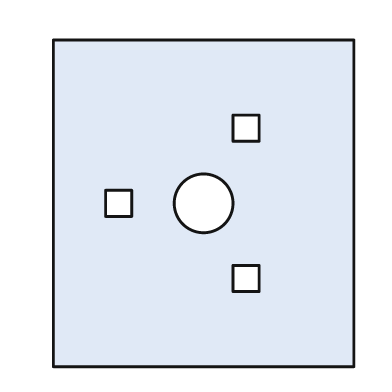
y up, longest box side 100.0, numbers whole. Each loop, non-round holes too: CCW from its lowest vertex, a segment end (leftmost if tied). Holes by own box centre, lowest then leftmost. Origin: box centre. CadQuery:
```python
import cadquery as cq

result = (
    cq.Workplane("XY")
    .moveTo(-46.0, -50.0)
    .lineTo(46.0, -50.0)
    .lineTo(46.0, 50.0)
    .lineTo(-46.0, 50.0)
    .close()
    .moveTo(9.0, -27.0)
    .lineTo(17.0, -27.0)
    .lineTo(17.0, -19.0)
    .lineTo(9.0, -19.0)
    .close()
    .moveTo(-30.0, -4.0)
    .lineTo(-22.0, -4.0)
    .lineTo(-22.0, 4.0)
    .lineTo(-30.0, 4.0)
    .close()
    .moveTo(0.0, 0.0)
    .circle(9.0)
    .moveTo(9.0, 19.0)
    .lineTo(17.0, 19.0)
    .lineTo(17.0, 27.0)
    .lineTo(9.0, 27.0)
    .close()
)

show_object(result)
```